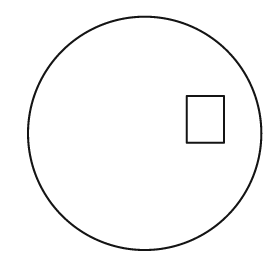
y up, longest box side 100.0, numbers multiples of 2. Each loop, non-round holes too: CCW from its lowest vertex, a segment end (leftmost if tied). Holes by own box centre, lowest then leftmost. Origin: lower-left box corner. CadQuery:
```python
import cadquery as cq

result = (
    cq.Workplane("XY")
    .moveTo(50.0, 50.0)
    .circle(50.0)
    .moveTo(68.0, 46.0)
    .lineTo(84.0, 46.0)
    .lineTo(84.0, 66.0)
    .lineTo(68.0, 66.0)
    .close()
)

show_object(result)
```